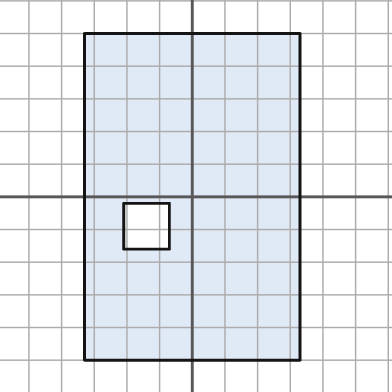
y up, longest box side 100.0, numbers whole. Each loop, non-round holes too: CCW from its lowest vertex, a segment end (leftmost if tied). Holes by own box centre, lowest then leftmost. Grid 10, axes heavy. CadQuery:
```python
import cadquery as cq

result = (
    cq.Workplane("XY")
    .moveTo(-33.0, -50.0)
    .lineTo(33.0, -50.0)
    .lineTo(33.0, 50.0)
    .lineTo(-33.0, 50.0)
    .close()
    .moveTo(-21.0, -16.0)
    .lineTo(-7.0, -16.0)
    .lineTo(-7.0, -2.0)
    .lineTo(-21.0, -2.0)
    .close()
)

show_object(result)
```